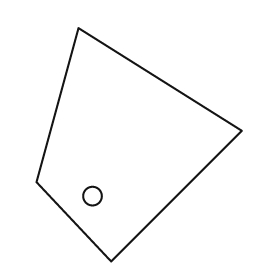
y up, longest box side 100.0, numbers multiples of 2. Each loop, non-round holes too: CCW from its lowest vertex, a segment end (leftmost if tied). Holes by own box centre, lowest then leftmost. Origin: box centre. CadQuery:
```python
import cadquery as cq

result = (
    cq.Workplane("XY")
    .moveTo(-12.0, -50.0)
    .lineTo(44.0, 6.0)
    .lineTo(-26.0, 50.0)
    .lineTo(-44.0, -16.0)
    .close()
    .moveTo(-20.0, -22.0)
    .circle(4.0)
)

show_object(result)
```